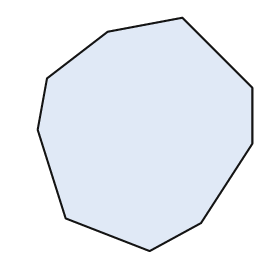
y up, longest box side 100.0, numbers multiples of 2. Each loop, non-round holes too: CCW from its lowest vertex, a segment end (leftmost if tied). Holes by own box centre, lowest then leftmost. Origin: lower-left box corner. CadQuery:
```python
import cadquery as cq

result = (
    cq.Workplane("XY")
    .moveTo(48.0, 0.0)
    .lineTo(70.0, 12.0)
    .lineTo(92.0, 46.0)
    .lineTo(92.0, 70.0)
    .lineTo(62.0, 100.0)
    .lineTo(30.0, 94.0)
    .lineTo(4.0, 74.0)
    .lineTo(0.0, 52.0)
    .lineTo(12.0, 14.0)
    .close()
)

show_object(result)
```